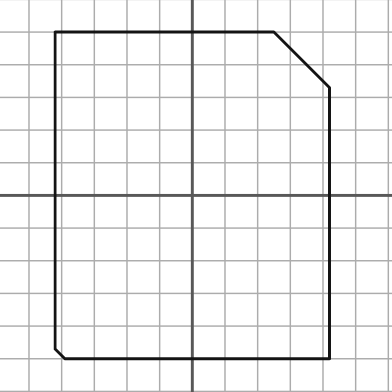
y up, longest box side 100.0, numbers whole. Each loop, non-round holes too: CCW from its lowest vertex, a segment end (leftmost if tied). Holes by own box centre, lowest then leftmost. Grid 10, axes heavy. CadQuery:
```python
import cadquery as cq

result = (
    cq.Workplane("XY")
    .moveTo(-39.0, -50.0)
    .lineTo(42.0, -50.0)
    .lineTo(42.0, 33.0)
    .lineTo(25.0, 50.0)
    .lineTo(-42.0, 50.0)
    .lineTo(-42.0, -47.0)
    .close()
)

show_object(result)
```